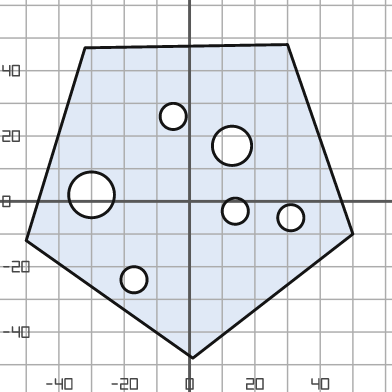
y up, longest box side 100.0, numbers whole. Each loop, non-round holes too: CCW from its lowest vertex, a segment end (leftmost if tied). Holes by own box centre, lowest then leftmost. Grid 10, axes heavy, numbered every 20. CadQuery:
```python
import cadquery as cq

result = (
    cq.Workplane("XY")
    .moveTo(1.0, -48.0)
    .lineTo(50.0, -10.0)
    .lineTo(30.0, 48.0)
    .lineTo(-32.0, 47.0)
    .lineTo(-50.0, -12.0)
    .close()
    .moveTo(-17.0, -24.0)
    .circle(4.0)
    .moveTo(31.0, -5.0)
    .circle(4.0)
    .moveTo(14.0, -3.0)
    .circle(4.0)
    .moveTo(-30.0, 2.0)
    .circle(7.0)
    .moveTo(13.0, 17.0)
    .circle(6.0)
    .moveTo(-5.0, 26.0)
    .circle(4.0)
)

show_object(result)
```